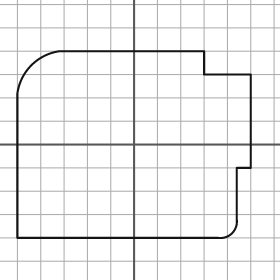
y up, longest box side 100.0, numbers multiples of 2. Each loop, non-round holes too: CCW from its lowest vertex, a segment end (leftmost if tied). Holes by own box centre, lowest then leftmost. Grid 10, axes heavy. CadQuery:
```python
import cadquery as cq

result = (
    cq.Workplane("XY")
    .moveTo(-50.0, -40.0)
    .lineTo(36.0, -40.0)
    .threePointArc((42.0, -38.0), (44.0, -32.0))
    .lineTo(44.0, -10.0)
    .lineTo(50.0, -10.0)
    .lineTo(50.0, 30.0)
    .lineTo(30.0, 30.0)
    .lineTo(30.0, 40.0)
    .lineTo(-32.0, 40.0)
    .threePointArc((-44.0, 34.0), (-50.0, 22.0))
    .close()
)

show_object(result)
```